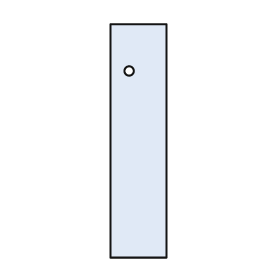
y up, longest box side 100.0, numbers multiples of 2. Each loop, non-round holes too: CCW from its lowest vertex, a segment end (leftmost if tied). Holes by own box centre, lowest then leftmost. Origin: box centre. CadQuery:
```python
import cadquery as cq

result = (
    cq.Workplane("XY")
    .moveTo(-12.0, -50.0)
    .lineTo(12.0, -50.0)
    .lineTo(12.0, 50.0)
    .lineTo(-12.0, 50.0)
    .close()
    .moveTo(-4.0, 30.0)
    .circle(2.0)
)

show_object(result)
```